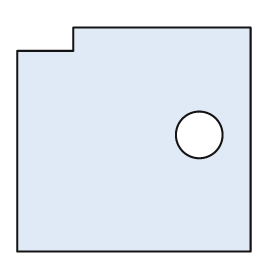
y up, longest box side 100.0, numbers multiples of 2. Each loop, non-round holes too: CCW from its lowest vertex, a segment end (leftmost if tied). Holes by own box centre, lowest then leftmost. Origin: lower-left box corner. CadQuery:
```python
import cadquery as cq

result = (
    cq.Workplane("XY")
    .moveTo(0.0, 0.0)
    .lineTo(100.0, 0.0)
    .lineTo(100.0, 96.0)
    .lineTo(24.0, 96.0)
    .lineTo(24.0, 86.0)
    .lineTo(0.0, 86.0)
    .close()
    .moveTo(78.0, 50.0)
    .circle(10.0)
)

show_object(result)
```